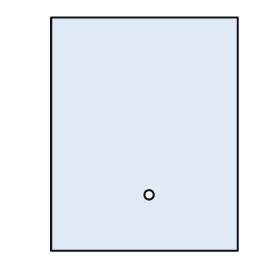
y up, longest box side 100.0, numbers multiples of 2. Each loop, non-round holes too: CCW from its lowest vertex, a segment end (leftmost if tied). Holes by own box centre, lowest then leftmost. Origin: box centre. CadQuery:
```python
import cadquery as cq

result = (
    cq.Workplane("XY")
    .moveTo(-40.0, -50.0)
    .lineTo(40.0, -50.0)
    .lineTo(40.0, 50.0)
    .lineTo(-40.0, 50.0)
    .close()
    .moveTo(2.0, -26.0)
    .circle(2.0)
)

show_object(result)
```